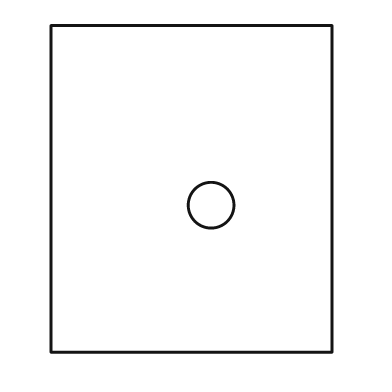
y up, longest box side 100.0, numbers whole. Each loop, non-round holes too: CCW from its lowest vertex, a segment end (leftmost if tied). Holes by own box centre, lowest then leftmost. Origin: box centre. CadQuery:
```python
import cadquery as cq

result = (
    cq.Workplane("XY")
    .moveTo(-43.0, -50.0)
    .lineTo(43.0, -50.0)
    .lineTo(43.0, 50.0)
    .lineTo(-43.0, 50.0)
    .close()
    .moveTo(6.0, -5.0)
    .circle(7.0)
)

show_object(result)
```